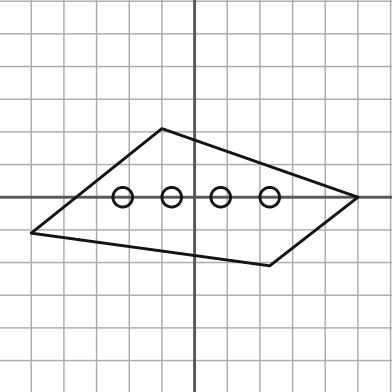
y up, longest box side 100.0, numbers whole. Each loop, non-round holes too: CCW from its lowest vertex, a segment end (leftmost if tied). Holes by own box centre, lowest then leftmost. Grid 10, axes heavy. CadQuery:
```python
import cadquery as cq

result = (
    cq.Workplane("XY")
    .moveTo(23.0, -21.0)
    .lineTo(50.0, 0.0)
    .lineTo(-10.0, 21.0)
    .lineTo(-50.0, -11.0)
    .close()
    .moveTo(-22.0, 0.0)
    .circle(3.0)
    .moveTo(-7.0, 0.0)
    .circle(3.0)
    .moveTo(8.0, 0.0)
    .circle(3.0)
    .moveTo(23.0, 0.0)
    .circle(3.0)
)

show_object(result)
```